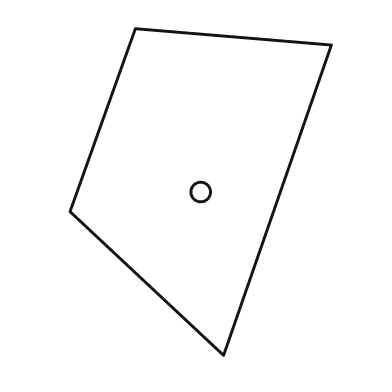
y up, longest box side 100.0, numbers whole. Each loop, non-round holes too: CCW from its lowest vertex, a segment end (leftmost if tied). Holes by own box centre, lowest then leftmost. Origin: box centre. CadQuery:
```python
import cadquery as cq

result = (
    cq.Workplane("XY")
    .moveTo(7.0, -50.0)
    .lineTo(40.0, 45.0)
    .lineTo(-20.0, 50.0)
    .lineTo(-40.0, -6.0)
    .close()
    .moveTo(0.0, 0.0)
    .circle(3.0)
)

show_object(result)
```